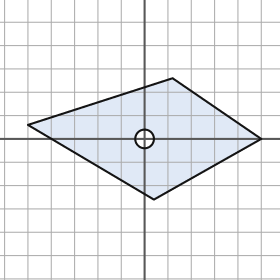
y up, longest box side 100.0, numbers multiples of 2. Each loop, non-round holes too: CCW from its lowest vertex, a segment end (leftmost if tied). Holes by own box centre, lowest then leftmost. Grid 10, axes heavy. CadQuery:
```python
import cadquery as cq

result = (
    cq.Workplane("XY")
    .moveTo(4.0, -26.0)
    .lineTo(50.0, 0.0)
    .lineTo(12.0, 26.0)
    .lineTo(-50.0, 6.0)
    .close()
    .moveTo(0.0, 0.0)
    .circle(4.0)
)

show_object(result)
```